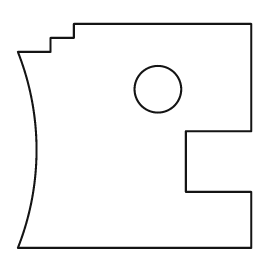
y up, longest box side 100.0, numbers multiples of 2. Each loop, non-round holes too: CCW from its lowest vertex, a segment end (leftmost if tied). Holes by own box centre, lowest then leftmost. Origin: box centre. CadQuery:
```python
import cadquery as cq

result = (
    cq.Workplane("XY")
    .moveTo(-50.0, -48.0)
    .lineTo(50.0, -48.0)
    .lineTo(50.0, -24.0)
    .lineTo(22.0, -24.0)
    .lineTo(22.0, 2.0)
    .lineTo(50.0, 2.0)
    .lineTo(50.0, 48.0)
    .lineTo(-26.0, 48.0)
    .lineTo(-26.0, 42.0)
    .lineTo(-36.0, 42.0)
    .lineTo(-36.0, 36.0)
    .lineTo(-50.0, 36.0)
    .threePointArc((-42.0, -6.0), (-50.0, -48.0))
    .close()
    .moveTo(10.0, 20.0)
    .circle(10.0)
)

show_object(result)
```